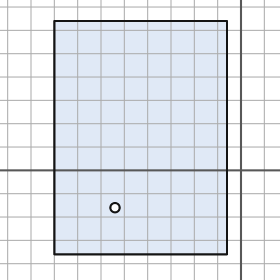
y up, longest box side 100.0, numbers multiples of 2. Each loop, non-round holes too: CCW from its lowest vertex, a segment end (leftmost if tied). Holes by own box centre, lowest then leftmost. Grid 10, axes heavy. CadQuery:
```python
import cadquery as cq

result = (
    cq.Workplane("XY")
    .moveTo(-80.0, -36.0)
    .lineTo(-6.0, -36.0)
    .lineTo(-6.0, 64.0)
    .lineTo(-80.0, 64.0)
    .close()
    .moveTo(-54.0, -16.0)
    .circle(2.0)
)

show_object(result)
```